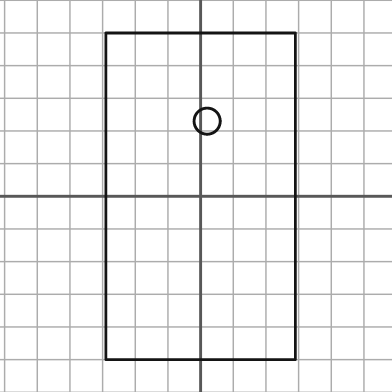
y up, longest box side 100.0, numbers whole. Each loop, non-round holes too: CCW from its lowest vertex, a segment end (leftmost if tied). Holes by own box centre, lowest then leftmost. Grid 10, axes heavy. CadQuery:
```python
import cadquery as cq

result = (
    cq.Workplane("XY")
    .moveTo(-29.0, -50.0)
    .lineTo(29.0, -50.0)
    .lineTo(29.0, 50.0)
    .lineTo(-29.0, 50.0)
    .close()
    .moveTo(2.0, 23.0)
    .circle(4.0)
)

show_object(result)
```